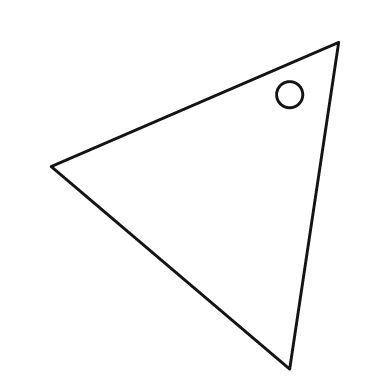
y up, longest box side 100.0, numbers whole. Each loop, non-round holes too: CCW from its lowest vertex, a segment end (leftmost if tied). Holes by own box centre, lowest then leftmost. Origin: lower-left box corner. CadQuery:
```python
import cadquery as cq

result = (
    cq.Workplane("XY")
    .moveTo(73.0, 0.0)
    .lineTo(88.0, 100.0)
    .lineTo(0.0, 62.0)
    .close()
    .moveTo(73.0, 84.0)
    .circle(4.0)
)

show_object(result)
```